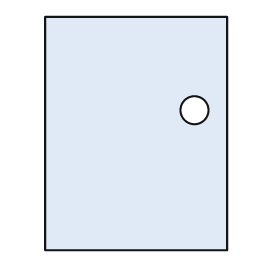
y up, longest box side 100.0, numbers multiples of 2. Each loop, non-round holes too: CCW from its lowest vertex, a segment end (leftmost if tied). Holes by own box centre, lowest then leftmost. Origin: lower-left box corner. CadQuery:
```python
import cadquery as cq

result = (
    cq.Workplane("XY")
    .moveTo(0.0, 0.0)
    .lineTo(78.0, 0.0)
    .lineTo(78.0, 100.0)
    .lineTo(0.0, 100.0)
    .close()
    .moveTo(64.0, 60.0)
    .circle(6.0)
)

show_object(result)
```